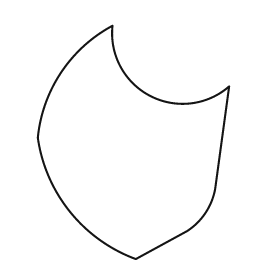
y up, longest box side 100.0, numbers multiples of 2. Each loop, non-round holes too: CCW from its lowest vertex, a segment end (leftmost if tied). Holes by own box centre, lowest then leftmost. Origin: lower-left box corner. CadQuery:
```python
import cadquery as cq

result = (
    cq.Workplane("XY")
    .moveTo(42.0, 0.0)
    .lineTo(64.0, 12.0)
    .threePointArc((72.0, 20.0), (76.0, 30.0))
    .lineTo(82.0, 74.0)
    .threePointArc((48.0, 70.0), (32.0, 100.0))
    .threePointArc((10.0, 80.0), (0.0, 52.0))
    .threePointArc((14.0, 20.0), (42.0, 0.0))
    .close()
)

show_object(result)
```